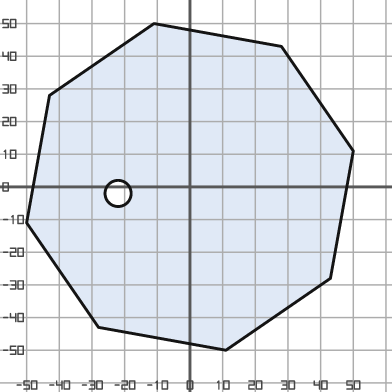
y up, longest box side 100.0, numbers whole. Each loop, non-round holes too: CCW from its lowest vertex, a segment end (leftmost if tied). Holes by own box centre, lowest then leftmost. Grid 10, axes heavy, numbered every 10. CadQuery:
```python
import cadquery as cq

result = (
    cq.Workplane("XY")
    .moveTo(11.0, -50.0)
    .lineTo(43.0, -28.0)
    .lineTo(50.0, 11.0)
    .lineTo(28.0, 43.0)
    .lineTo(-11.0, 50.0)
    .lineTo(-43.0, 28.0)
    .lineTo(-50.0, -11.0)
    .lineTo(-28.0, -43.0)
    .close()
    .moveTo(-22.0, -2.0)
    .circle(4.0)
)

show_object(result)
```